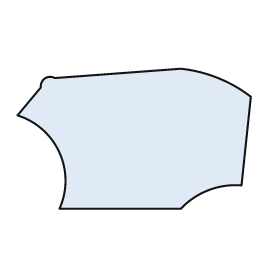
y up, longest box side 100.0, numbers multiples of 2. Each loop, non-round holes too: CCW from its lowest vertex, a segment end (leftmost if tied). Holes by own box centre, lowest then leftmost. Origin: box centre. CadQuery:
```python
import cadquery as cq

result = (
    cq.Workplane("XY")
    .moveTo(-32.0, -30.0)
    .lineTo(20.0, -30.0)
    .threePointArc((32.0, -22.0), (46.0, -20.0))
    .lineTo(50.0, 18.0)
    .threePointArc((36.0, 26.0), (20.0, 30.0))
    .lineTo(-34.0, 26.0)
    .threePointArc((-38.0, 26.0), (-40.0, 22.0))
    .lineTo(-50.0, 10.0)
    .threePointArc((-32.0, -6.0), (-32.0, -30.0))
    .close()
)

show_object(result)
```